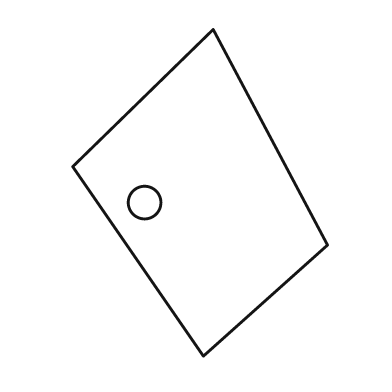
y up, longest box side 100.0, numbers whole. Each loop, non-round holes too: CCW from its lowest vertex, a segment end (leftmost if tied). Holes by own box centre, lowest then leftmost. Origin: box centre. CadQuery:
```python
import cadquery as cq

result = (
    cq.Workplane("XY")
    .moveTo(1.0, -50.0)
    .lineTo(39.0, -16.0)
    .lineTo(4.0, 50.0)
    .lineTo(-39.0, 8.0)
    .close()
    .moveTo(-17.0, -3.0)
    .circle(5.0)
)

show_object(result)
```